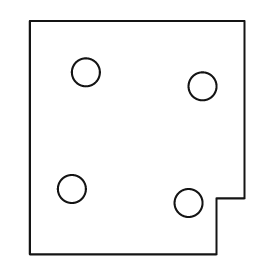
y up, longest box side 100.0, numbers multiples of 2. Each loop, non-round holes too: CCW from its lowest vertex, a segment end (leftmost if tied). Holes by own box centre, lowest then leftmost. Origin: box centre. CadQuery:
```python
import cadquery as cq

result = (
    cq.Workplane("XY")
    .moveTo(-46.0, -50.0)
    .lineTo(34.0, -50.0)
    .lineTo(34.0, -26.0)
    .lineTo(46.0, -26.0)
    .lineTo(46.0, 50.0)
    .lineTo(-46.0, 50.0)
    .close()
    .moveTo(22.0, -28.0)
    .circle(6.0)
    .moveTo(-28.0, -22.0)
    .circle(6.0)
    .moveTo(28.0, 22.0)
    .circle(6.0)
    .moveTo(-22.0, 28.0)
    .circle(6.0)
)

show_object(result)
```